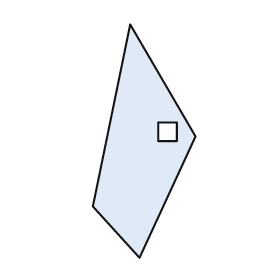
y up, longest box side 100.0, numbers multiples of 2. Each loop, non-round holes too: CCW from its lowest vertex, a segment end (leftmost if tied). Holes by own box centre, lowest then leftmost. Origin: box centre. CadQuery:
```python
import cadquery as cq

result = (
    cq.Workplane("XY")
    .moveTo(-2.0, -50.0)
    .lineTo(22.0, 2.0)
    .lineTo(-6.0, 50.0)
    .lineTo(-22.0, -28.0)
    .close()
    .moveTo(6.0, 0.0)
    .lineTo(14.0, 0.0)
    .lineTo(14.0, 8.0)
    .lineTo(6.0, 8.0)
    .close()
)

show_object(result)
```